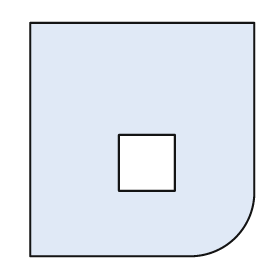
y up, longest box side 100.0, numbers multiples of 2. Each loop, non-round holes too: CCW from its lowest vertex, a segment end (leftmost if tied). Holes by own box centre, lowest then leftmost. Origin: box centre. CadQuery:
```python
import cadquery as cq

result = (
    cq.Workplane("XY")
    .moveTo(-48.0, -50.0)
    .lineTo(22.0, -50.0)
    .threePointArc((40.0, -42.0), (48.0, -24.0))
    .lineTo(48.0, 50.0)
    .lineTo(-48.0, 50.0)
    .close()
    .moveTo(-10.0, -22.0)
    .lineTo(14.0, -22.0)
    .lineTo(14.0, 2.0)
    .lineTo(-10.0, 2.0)
    .close()
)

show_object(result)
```